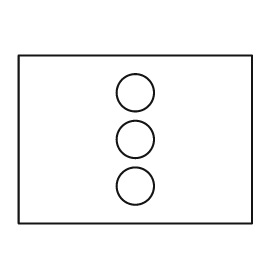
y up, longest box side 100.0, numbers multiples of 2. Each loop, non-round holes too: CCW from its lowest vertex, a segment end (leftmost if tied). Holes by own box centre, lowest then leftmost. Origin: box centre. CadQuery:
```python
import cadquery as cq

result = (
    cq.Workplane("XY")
    .moveTo(-50.0, -36.0)
    .lineTo(50.0, -36.0)
    .lineTo(50.0, 36.0)
    .lineTo(-50.0, 36.0)
    .close()
    .moveTo(0.0, -20.0)
    .circle(8.0)
    .moveTo(0.0, 0.0)
    .circle(8.0)
    .moveTo(0.0, 20.0)
    .circle(8.0)
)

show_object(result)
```